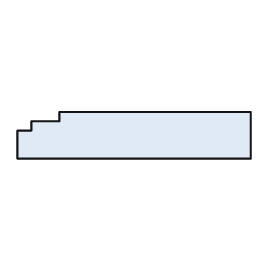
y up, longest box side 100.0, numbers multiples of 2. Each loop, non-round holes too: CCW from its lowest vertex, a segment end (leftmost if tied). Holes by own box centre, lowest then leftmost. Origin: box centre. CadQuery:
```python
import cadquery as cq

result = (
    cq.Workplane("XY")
    .moveTo(-50.0, -10.0)
    .lineTo(50.0, -10.0)
    .lineTo(50.0, 10.0)
    .lineTo(-32.0, 10.0)
    .lineTo(-32.0, 6.0)
    .lineTo(-44.0, 6.0)
    .lineTo(-44.0, 2.0)
    .lineTo(-50.0, 2.0)
    .close()
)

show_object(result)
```